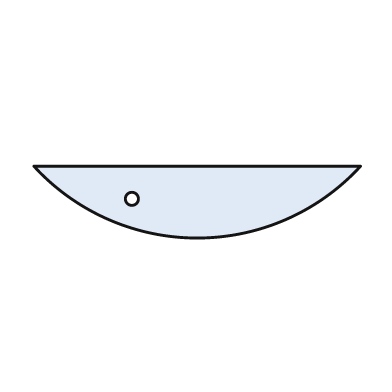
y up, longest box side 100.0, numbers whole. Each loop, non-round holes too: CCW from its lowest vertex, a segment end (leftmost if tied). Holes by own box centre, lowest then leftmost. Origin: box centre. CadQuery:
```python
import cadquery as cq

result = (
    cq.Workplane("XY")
    .moveTo(-50.0, 11.0)
    .threePointArc((0.0, -11.0), (50.0, 11.0))
    .close()
    .moveTo(-20.0, 1.0)
    .circle(2.0)
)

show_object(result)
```